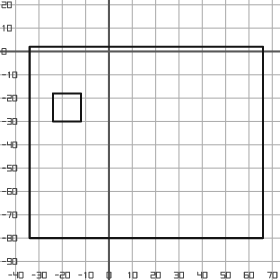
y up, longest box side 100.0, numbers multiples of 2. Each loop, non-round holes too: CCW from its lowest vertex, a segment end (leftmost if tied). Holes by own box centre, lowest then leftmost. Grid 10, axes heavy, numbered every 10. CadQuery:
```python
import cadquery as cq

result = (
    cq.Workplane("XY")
    .moveTo(-34.0, -80.0)
    .lineTo(66.0, -80.0)
    .lineTo(66.0, 2.0)
    .lineTo(-34.0, 2.0)
    .close()
    .moveTo(-24.0, -30.0)
    .lineTo(-12.0, -30.0)
    .lineTo(-12.0, -18.0)
    .lineTo(-24.0, -18.0)
    .close()
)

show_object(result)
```